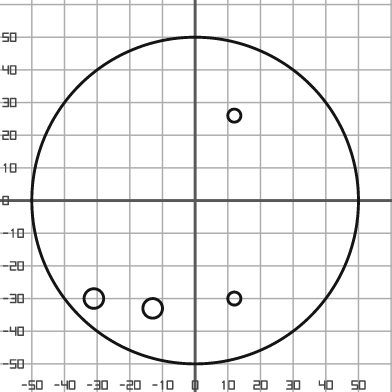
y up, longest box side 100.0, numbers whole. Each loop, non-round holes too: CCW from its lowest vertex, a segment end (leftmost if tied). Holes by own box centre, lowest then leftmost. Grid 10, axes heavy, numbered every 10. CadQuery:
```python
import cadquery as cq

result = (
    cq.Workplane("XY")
    .moveTo(0.0, 0.0)
    .circle(50.0)
    .moveTo(-13.0, -33.0)
    .circle(3.0)
    .moveTo(-31.0, -30.0)
    .circle(3.0)
    .moveTo(12.0, -30.0)
    .circle(2.0)
    .moveTo(12.0, 26.0)
    .circle(2.0)
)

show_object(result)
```